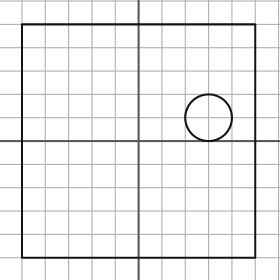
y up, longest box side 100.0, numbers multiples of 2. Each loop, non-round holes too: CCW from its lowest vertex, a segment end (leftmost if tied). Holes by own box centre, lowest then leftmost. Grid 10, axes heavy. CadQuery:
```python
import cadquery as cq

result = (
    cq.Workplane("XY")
    .moveTo(-50.0, -50.0)
    .lineTo(50.0, -50.0)
    .lineTo(50.0, 50.0)
    .lineTo(-50.0, 50.0)
    .close()
    .moveTo(30.0, 10.0)
    .circle(10.0)
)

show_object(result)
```